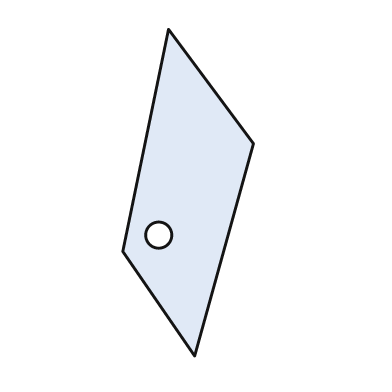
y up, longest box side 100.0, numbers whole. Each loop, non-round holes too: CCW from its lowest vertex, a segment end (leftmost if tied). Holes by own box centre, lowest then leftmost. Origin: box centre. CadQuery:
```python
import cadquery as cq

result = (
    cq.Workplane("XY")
    .moveTo(2.0, -50.0)
    .lineTo(20.0, 15.0)
    .lineTo(-6.0, 50.0)
    .lineTo(-20.0, -18.0)
    .close()
    .moveTo(-9.0, -13.0)
    .circle(4.0)
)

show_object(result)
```